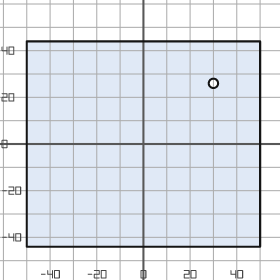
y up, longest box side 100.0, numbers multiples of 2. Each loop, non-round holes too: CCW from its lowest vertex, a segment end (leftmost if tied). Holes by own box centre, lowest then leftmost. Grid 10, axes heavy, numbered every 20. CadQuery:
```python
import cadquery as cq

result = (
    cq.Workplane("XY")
    .moveTo(-50.0, -44.0)
    .lineTo(50.0, -44.0)
    .lineTo(50.0, 44.0)
    .lineTo(-50.0, 44.0)
    .close()
    .moveTo(30.0, 26.0)
    .circle(2.0)
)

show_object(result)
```